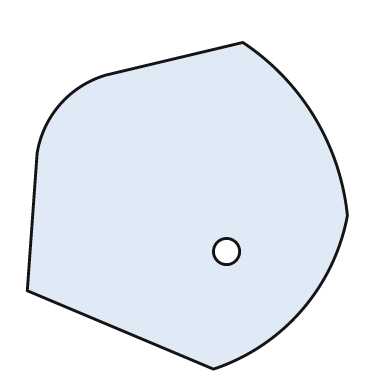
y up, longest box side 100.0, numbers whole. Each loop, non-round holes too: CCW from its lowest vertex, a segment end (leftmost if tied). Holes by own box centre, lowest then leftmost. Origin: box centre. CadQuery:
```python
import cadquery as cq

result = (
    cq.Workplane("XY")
    .moveTo(8.0, -50.0)
    .threePointArc((35.0, -32.0), (49.0, -3.0))
    .threePointArc((39.0, 27.0), (17.0, 50.0))
    .lineTo(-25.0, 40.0)
    .threePointArc((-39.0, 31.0), (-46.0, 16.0))
    .lineTo(-49.0, -26.0)
    .close()
    .moveTo(12.0, -14.0)
    .circle(4.0)
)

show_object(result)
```